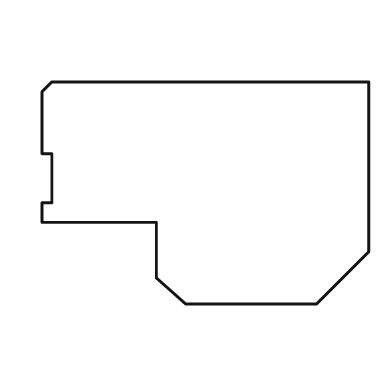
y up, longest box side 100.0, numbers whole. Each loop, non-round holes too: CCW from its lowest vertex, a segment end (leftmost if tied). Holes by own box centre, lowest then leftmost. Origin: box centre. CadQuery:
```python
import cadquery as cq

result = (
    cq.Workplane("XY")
    .moveTo(-6.0, -34.0)
    .lineTo(34.0, -34.0)
    .lineTo(50.0, -18.0)
    .lineTo(50.0, 34.0)
    .lineTo(-47.0, 34.0)
    .lineTo(-50.0, 31.0)
    .lineTo(-50.0, 12.0)
    .lineTo(-47.0, 12.0)
    .lineTo(-47.0, -3.0)
    .lineTo(-50.0, -3.0)
    .lineTo(-50.0, -9.0)
    .lineTo(-15.0, -9.0)
    .lineTo(-15.0, -26.0)
    .close()
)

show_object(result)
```